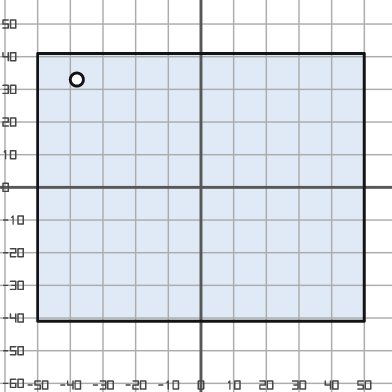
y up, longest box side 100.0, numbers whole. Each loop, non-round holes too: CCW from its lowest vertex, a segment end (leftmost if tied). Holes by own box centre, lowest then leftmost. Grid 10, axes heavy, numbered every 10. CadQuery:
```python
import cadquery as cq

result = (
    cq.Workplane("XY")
    .moveTo(-50.0, -41.0)
    .lineTo(50.0, -41.0)
    .lineTo(50.0, 41.0)
    .lineTo(-50.0, 41.0)
    .close()
    .moveTo(-38.0, 33.0)
    .circle(2.0)
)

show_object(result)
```